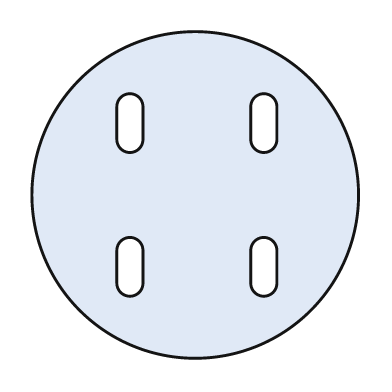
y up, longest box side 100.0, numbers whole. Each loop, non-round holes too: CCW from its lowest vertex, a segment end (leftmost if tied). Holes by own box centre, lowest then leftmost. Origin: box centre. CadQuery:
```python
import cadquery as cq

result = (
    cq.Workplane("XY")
    .moveTo(0.0, 0.0)
    .circle(50.0)
    .moveTo(-24.0, -27.0)
    .threePointArc((-20.0, -31.0), (-16.0, -27.0))
    .lineTo(-16.0, -17.0)
    .threePointArc((-20.0, -13.0), (-24.0, -17.0))
    .close()
    .moveTo(17.0, -27.0)
    .threePointArc((21.0, -31.0), (25.0, -27.0))
    .lineTo(25.0, -17.0)
    .threePointArc((21.0, -13.0), (17.0, -17.0))
    .close()
    .moveTo(-24.0, 17.0)
    .threePointArc((-20.0, 13.0), (-16.0, 17.0))
    .lineTo(-16.0, 27.0)
    .threePointArc((-20.0, 31.0), (-24.0, 27.0))
    .close()
    .moveTo(17.0, 17.0)
    .threePointArc((21.0, 13.0), (25.0, 17.0))
    .lineTo(25.0, 27.0)
    .threePointArc((21.0, 31.0), (17.0, 27.0))
    .close()
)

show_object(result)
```